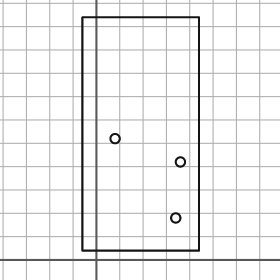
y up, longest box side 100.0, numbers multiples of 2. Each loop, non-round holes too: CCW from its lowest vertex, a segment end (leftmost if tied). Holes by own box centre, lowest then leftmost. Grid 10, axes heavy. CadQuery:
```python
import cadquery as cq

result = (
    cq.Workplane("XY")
    .moveTo(-6.0, 4.0)
    .lineTo(44.0, 4.0)
    .lineTo(44.0, 104.0)
    .lineTo(-6.0, 104.0)
    .close()
    .moveTo(34.0, 18.0)
    .circle(2.0)
    .moveTo(36.0, 42.0)
    .circle(2.0)
    .moveTo(8.0, 52.0)
    .circle(2.0)
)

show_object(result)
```